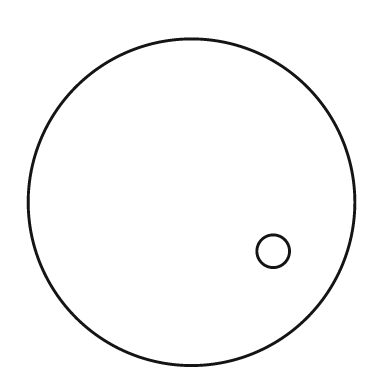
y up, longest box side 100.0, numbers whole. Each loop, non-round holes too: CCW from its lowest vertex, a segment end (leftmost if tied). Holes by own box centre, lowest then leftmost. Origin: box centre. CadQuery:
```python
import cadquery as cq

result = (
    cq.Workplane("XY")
    .moveTo(0.0, 0.0)
    .circle(50.0)
    .moveTo(25.0, -15.0)
    .circle(5.0)
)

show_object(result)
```